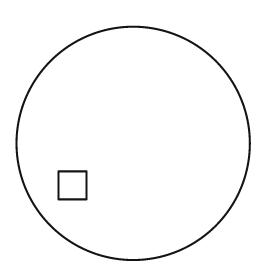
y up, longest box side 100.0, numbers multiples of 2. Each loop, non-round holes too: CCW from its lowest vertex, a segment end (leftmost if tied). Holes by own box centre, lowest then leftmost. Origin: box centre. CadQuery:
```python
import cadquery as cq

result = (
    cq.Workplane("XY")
    .moveTo(0.0, 0.0)
    .circle(50.0)
    .moveTo(-32.0, -24.0)
    .lineTo(-20.0, -24.0)
    .lineTo(-20.0, -12.0)
    .lineTo(-32.0, -12.0)
    .close()
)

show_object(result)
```